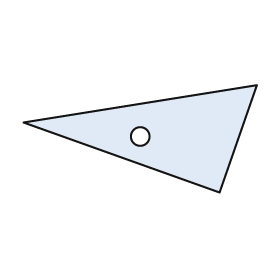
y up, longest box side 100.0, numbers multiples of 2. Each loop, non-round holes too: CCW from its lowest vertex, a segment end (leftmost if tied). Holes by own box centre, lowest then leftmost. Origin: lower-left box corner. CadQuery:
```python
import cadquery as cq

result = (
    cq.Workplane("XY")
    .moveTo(84.0, 0.0)
    .lineTo(100.0, 46.0)
    .lineTo(0.0, 30.0)
    .close()
    .moveTo(50.0, 24.0)
    .circle(4.0)
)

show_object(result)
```